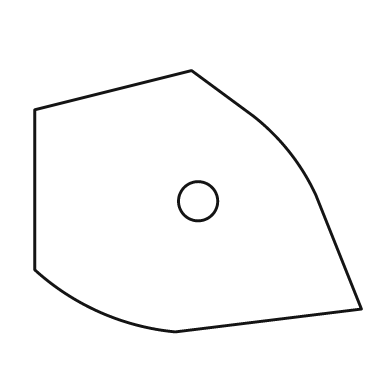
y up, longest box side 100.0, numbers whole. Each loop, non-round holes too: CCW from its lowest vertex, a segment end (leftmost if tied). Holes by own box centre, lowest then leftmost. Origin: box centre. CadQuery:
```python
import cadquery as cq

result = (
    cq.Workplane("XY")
    .moveTo(-7.0, -40.0)
    .lineTo(50.0, -33.0)
    .lineTo(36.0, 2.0)
    .threePointArc((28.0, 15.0), (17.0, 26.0))
    .lineTo(-2.0, 40.0)
    .lineTo(-50.0, 28.0)
    .lineTo(-50.0, -21.0)
    .threePointArc((-30.0, -34.0), (-7.0, -40.0))
    .close()
    .moveTo(0.0, 0.0)
    .circle(6.0)
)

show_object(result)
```